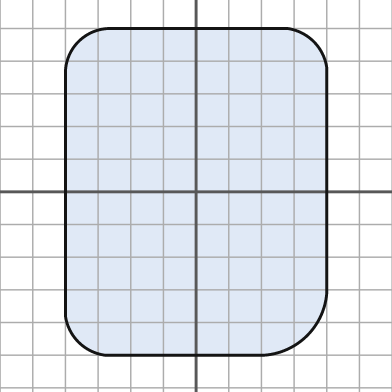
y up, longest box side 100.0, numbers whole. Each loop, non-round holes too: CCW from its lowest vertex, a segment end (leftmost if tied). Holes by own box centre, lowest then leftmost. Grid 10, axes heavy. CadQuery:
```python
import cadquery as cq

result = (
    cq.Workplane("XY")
    .moveTo(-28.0, -50.0)
    .lineTo(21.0, -50.0)
    .threePointArc((34.0, -44.0), (40.0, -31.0))
    .lineTo(40.0, 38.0)
    .threePointArc((36.0, 46.0), (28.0, 50.0))
    .lineTo(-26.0, 50.0)
    .threePointArc((-36.0, 46.0), (-40.0, 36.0))
    .lineTo(-40.0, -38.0)
    .threePointArc((-36.0, -46.0), (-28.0, -50.0))
    .close()
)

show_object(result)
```